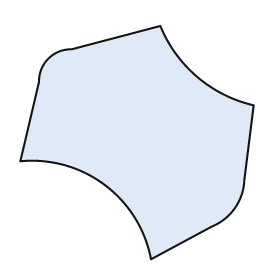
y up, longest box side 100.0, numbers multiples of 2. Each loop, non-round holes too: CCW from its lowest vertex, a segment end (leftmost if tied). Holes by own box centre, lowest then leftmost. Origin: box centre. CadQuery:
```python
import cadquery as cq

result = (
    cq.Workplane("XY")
    .moveTo(6.0, -50.0)
    .lineTo(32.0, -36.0)
    .threePointArc((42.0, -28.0), (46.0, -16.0))
    .lineTo(50.0, 16.0)
    .threePointArc((26.0, 28.0), (10.0, 50.0))
    .lineTo(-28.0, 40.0)
    .threePointArc((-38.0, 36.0), (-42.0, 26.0))
    .lineTo(-50.0, -8.0)
    .threePointArc((-14.0, -18.0), (6.0, -50.0))
    .close()
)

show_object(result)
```